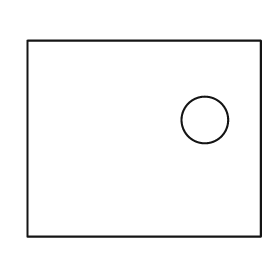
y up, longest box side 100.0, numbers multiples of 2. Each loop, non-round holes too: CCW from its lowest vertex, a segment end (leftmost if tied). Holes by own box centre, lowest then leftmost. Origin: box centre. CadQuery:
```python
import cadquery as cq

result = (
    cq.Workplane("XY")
    .moveTo(-50.0, -42.0)
    .lineTo(50.0, -42.0)
    .lineTo(50.0, 42.0)
    .lineTo(-50.0, 42.0)
    .close()
    .moveTo(26.0, 8.0)
    .circle(10.0)
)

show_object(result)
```